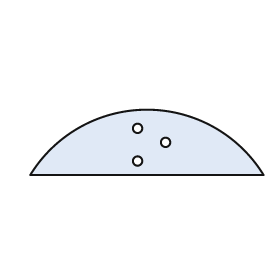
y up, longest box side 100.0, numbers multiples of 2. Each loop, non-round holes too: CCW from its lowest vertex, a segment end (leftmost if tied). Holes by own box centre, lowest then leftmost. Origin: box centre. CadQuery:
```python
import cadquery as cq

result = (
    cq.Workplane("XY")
    .moveTo(-50.0, -14.0)
    .lineTo(50.0, -14.0)
    .threePointArc((0.0, 14.0), (-50.0, -14.0))
    .close()
    .moveTo(-4.0, -8.0)
    .circle(2.0)
    .moveTo(8.0, 0.0)
    .circle(2.0)
    .moveTo(-4.0, 6.0)
    .circle(2.0)
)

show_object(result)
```